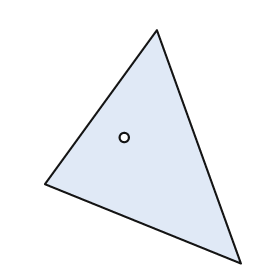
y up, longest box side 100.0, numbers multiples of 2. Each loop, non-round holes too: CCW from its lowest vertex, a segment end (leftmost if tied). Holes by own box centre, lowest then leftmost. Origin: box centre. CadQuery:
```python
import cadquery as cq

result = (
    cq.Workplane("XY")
    .moveTo(42.0, -50.0)
    .lineTo(6.0, 50.0)
    .lineTo(-42.0, -16.0)
    .close()
    .moveTo(-8.0, 4.0)
    .circle(2.0)
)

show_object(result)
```